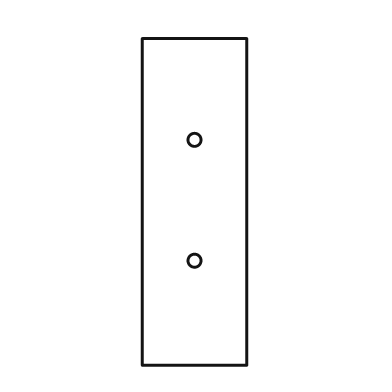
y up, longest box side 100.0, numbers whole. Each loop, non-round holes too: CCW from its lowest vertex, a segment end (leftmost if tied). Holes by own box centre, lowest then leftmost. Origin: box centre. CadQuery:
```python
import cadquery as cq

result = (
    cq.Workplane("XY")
    .moveTo(-16.0, -50.0)
    .lineTo(16.0, -50.0)
    .lineTo(16.0, 50.0)
    .lineTo(-16.0, 50.0)
    .close()
    .moveTo(0.0, -18.0)
    .circle(2.0)
    .moveTo(0.0, 19.0)
    .circle(2.0)
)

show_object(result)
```